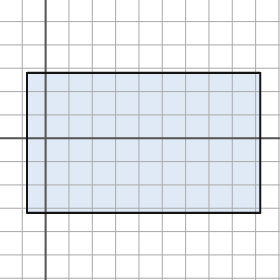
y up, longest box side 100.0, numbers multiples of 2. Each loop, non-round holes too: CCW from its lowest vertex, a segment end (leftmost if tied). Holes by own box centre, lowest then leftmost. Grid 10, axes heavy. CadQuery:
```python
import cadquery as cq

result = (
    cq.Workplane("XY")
    .moveTo(-8.0, -32.0)
    .lineTo(92.0, -32.0)
    .lineTo(92.0, 28.0)
    .lineTo(-8.0, 28.0)
    .close()
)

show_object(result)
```